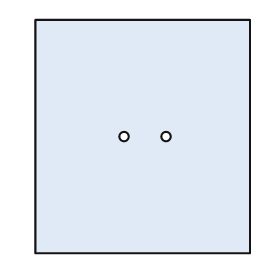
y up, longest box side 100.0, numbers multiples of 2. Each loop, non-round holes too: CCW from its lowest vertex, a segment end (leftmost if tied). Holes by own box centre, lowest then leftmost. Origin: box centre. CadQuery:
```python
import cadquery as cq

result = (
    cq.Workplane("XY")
    .moveTo(-46.0, -50.0)
    .lineTo(46.0, -50.0)
    .lineTo(46.0, 50.0)
    .lineTo(-46.0, 50.0)
    .close()
    .moveTo(-8.0, 0.0)
    .circle(2.0)
    .moveTo(10.0, 0.0)
    .circle(2.0)
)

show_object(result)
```